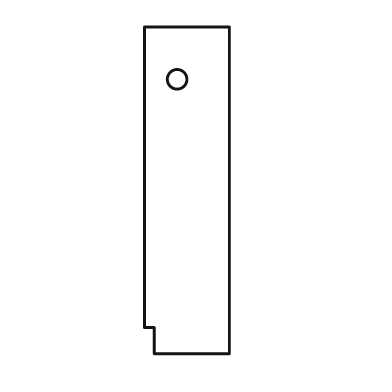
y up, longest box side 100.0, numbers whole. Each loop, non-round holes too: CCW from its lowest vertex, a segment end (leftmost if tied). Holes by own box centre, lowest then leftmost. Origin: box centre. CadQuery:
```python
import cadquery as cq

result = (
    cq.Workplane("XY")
    .moveTo(-10.0, -50.0)
    .lineTo(13.0, -50.0)
    .lineTo(13.0, 50.0)
    .lineTo(-13.0, 50.0)
    .lineTo(-13.0, -42.0)
    .lineTo(-10.0, -42.0)
    .close()
    .moveTo(-3.0, 34.0)
    .circle(3.0)
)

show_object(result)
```